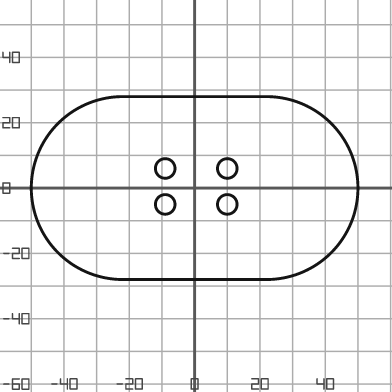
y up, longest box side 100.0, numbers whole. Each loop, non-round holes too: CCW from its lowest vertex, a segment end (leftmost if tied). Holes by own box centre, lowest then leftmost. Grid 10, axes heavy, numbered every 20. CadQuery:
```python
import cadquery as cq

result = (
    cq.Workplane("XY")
    .moveTo(-22.0, -28.0)
    .lineTo(22.0, -28.0)
    .threePointArc((50.0, 0.0), (22.0, 28.0))
    .lineTo(-22.0, 28.0)
    .threePointArc((-50.0, 0.0), (-22.0, -28.0))
    .close()
    .moveTo(-9.0, -5.0)
    .circle(3.0)
    .moveTo(10.0, -5.0)
    .circle(3.0)
    .moveTo(-9.0, 6.0)
    .circle(3.0)
    .moveTo(10.0, 6.0)
    .circle(3.0)
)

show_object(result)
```